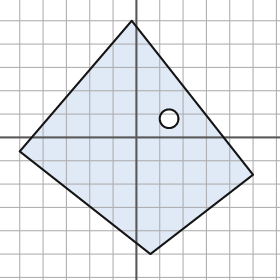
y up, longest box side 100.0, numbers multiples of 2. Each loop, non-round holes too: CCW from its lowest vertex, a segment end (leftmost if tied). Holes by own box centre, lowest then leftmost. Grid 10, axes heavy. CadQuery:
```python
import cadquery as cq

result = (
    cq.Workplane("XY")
    .moveTo(6.0, -50.0)
    .lineTo(50.0, -16.0)
    .lineTo(-2.0, 50.0)
    .lineTo(-50.0, -6.0)
    .close()
    .moveTo(14.0, 8.0)
    .circle(4.0)
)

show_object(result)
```